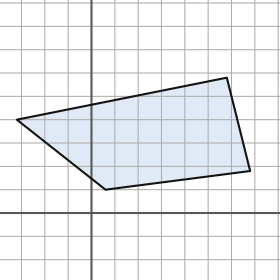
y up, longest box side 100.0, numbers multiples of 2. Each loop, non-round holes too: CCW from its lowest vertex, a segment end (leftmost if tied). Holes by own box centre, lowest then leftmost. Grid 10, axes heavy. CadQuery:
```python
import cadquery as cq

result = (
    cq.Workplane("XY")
    .moveTo(6.0, 10.0)
    .lineTo(68.0, 18.0)
    .lineTo(58.0, 58.0)
    .lineTo(-32.0, 40.0)
    .close()
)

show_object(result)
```